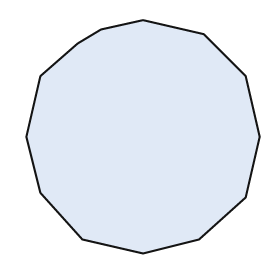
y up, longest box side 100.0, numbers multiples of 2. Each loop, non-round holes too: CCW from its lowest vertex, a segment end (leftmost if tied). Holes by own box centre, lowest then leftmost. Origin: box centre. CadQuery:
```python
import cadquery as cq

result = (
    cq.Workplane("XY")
    .moveTo(0.0, -50.0)
    .lineTo(24.0, -44.0)
    .lineTo(44.0, -26.0)
    .lineTo(50.0, 0.0)
    .lineTo(44.0, 26.0)
    .lineTo(26.0, 44.0)
    .lineTo(0.0, 50.0)
    .lineTo(-18.0, 46.0)
    .lineTo(-28.0, 40.0)
    .lineTo(-44.0, 26.0)
    .lineTo(-50.0, 0.0)
    .lineTo(-44.0, -24.0)
    .lineTo(-26.0, -44.0)
    .close()
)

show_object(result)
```